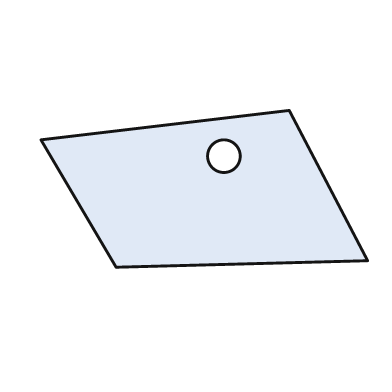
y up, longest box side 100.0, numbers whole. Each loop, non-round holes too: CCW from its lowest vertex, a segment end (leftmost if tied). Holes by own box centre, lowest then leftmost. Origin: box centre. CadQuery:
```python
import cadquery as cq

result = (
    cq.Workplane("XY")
    .moveTo(-27.0, -24.0)
    .lineTo(50.0, -22.0)
    .lineTo(26.0, 24.0)
    .lineTo(-50.0, 15.0)
    .close()
    .moveTo(6.0, 10.0)
    .circle(5.0)
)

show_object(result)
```